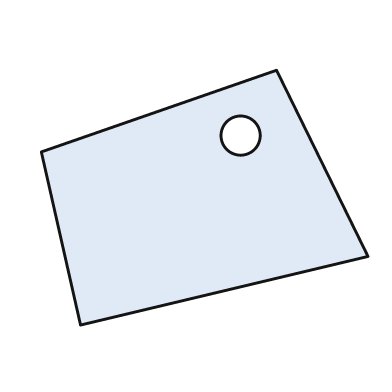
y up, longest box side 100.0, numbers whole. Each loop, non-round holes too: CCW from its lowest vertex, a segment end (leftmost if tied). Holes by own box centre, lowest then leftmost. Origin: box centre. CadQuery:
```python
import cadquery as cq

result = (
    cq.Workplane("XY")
    .moveTo(-38.0, -39.0)
    .lineTo(50.0, -18.0)
    .lineTo(22.0, 39.0)
    .lineTo(-50.0, 14.0)
    .close()
    .moveTo(11.0, 19.0)
    .circle(6.0)
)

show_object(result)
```